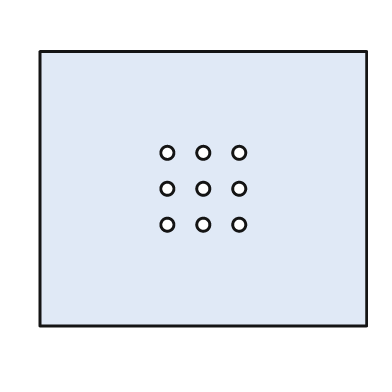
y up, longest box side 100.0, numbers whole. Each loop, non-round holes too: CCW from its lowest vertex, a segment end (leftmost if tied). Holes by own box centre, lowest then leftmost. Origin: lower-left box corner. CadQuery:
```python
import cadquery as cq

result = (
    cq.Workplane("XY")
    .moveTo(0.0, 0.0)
    .lineTo(100.0, 0.0)
    .lineTo(100.0, 84.0)
    .lineTo(0.0, 84.0)
    .close()
    .moveTo(39.0, 31.0)
    .circle(2.0)
    .moveTo(50.0, 31.0)
    .circle(2.0)
    .moveTo(61.0, 31.0)
    .circle(2.0)
    .moveTo(39.0, 42.0)
    .circle(2.0)
    .moveTo(50.0, 42.0)
    .circle(2.0)
    .moveTo(61.0, 42.0)
    .circle(2.0)
    .moveTo(39.0, 53.0)
    .circle(2.0)
    .moveTo(50.0, 53.0)
    .circle(2.0)
    .moveTo(61.0, 53.0)
    .circle(2.0)
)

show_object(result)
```